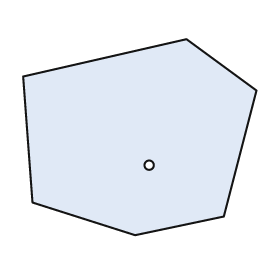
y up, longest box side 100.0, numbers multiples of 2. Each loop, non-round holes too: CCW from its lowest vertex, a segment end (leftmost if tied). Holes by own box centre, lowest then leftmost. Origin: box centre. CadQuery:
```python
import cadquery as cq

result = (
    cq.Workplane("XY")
    .moveTo(-2.0, -42.0)
    .lineTo(36.0, -34.0)
    .lineTo(50.0, 20.0)
    .lineTo(20.0, 42.0)
    .lineTo(-50.0, 26.0)
    .lineTo(-46.0, -28.0)
    .close()
    .moveTo(4.0, -12.0)
    .circle(2.0)
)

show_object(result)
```